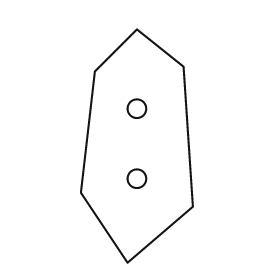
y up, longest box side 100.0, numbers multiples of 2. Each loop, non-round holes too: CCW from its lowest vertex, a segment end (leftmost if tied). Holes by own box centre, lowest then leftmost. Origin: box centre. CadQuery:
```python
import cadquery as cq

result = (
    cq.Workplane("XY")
    .moveTo(-4.0, -50.0)
    .lineTo(24.0, -26.0)
    .lineTo(20.0, 34.0)
    .lineTo(0.0, 50.0)
    .lineTo(-18.0, 32.0)
    .lineTo(-24.0, -20.0)
    .close()
    .moveTo(0.0, -14.0)
    .circle(4.0)
    .moveTo(0.0, 16.0)
    .circle(4.0)
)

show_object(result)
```